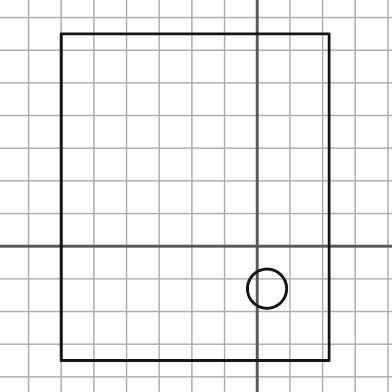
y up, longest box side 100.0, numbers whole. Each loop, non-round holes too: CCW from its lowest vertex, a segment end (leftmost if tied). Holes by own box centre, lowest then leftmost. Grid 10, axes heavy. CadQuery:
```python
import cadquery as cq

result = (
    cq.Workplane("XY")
    .moveTo(-60.0, -35.0)
    .lineTo(22.0, -35.0)
    .lineTo(22.0, 65.0)
    .lineTo(-60.0, 65.0)
    .close()
    .moveTo(3.0, -13.0)
    .circle(6.0)
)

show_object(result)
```